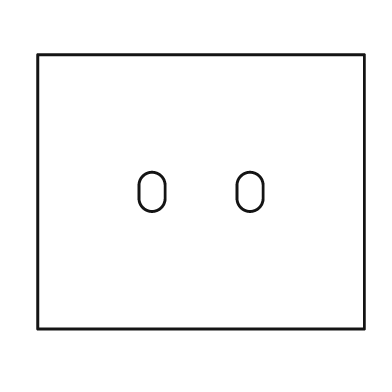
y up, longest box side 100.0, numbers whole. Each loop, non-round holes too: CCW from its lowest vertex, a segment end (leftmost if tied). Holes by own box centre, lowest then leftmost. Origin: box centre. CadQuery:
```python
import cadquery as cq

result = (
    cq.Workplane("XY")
    .moveTo(-50.0, -42.0)
    .lineTo(50.0, -42.0)
    .lineTo(50.0, 42.0)
    .lineTo(-50.0, 42.0)
    .close()
    .moveTo(-19.0, -2.0)
    .threePointArc((-15.0, -6.0), (-11.0, -2.0))
    .lineTo(-11.0, 2.0)
    .threePointArc((-15.0, 6.0), (-19.0, 2.0))
    .close()
    .moveTo(11.0, -2.0)
    .threePointArc((15.0, -6.0), (19.0, -2.0))
    .lineTo(19.0, 2.0)
    .threePointArc((15.0, 6.0), (11.0, 2.0))
    .close()
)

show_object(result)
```